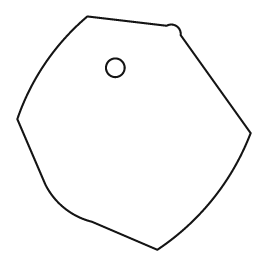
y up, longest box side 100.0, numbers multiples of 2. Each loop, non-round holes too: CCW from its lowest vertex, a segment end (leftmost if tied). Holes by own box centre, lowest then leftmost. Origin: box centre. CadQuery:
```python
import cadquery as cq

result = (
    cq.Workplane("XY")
    .moveTo(10.0, -50.0)
    .threePointArc((34.0, -28.0), (50.0, 0.0))
    .lineTo(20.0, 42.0)
    .threePointArc((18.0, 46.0), (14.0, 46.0))
    .lineTo(-20.0, 50.0)
    .threePointArc((-38.0, 30.0), (-50.0, 6.0))
    .lineTo(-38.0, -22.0)
    .threePointArc((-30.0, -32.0), (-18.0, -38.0))
    .close()
    .moveTo(-8.0, 28.0)
    .circle(4.0)
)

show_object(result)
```